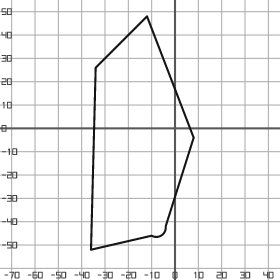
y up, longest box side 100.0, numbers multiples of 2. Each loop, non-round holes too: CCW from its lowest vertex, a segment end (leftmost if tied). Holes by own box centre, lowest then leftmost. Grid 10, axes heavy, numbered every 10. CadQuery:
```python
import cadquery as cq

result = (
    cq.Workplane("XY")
    .moveTo(-36.0, -52.0)
    .lineTo(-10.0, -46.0)
    .threePointArc((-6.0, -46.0), (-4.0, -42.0))
    .lineTo(8.0, -4.0)
    .lineTo(-12.0, 48.0)
    .lineTo(-34.0, 26.0)
    .close()
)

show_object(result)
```